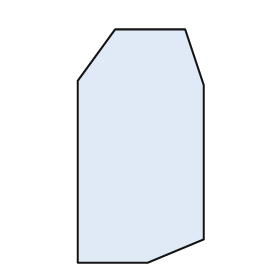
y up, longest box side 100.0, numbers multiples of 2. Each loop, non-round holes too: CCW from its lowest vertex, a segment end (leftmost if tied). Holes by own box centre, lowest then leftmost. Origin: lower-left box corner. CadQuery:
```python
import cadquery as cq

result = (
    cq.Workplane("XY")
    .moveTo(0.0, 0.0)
    .lineTo(30.0, 0.0)
    .lineTo(54.0, 10.0)
    .lineTo(54.0, 76.0)
    .lineTo(46.0, 100.0)
    .lineTo(16.0, 100.0)
    .lineTo(0.0, 78.0)
    .close()
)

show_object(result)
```